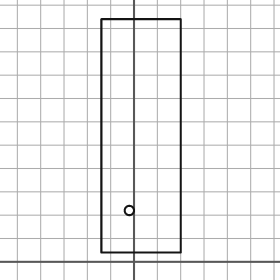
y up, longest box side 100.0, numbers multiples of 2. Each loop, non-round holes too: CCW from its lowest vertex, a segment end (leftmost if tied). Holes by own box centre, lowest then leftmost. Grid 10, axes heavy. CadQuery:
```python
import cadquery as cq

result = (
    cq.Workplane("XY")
    .moveTo(-14.0, 4.0)
    .lineTo(20.0, 4.0)
    .lineTo(20.0, 104.0)
    .lineTo(-14.0, 104.0)
    .close()
    .moveTo(-2.0, 22.0)
    .circle(2.0)
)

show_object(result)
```